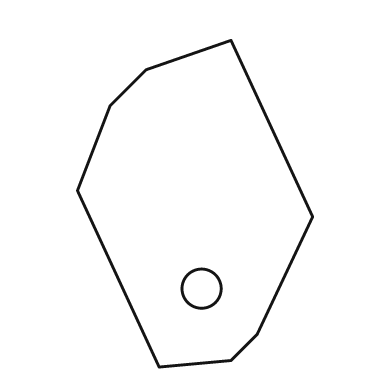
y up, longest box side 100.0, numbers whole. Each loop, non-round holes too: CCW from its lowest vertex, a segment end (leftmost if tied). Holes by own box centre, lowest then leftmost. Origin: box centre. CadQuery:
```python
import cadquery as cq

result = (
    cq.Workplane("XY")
    .moveTo(-11.0, -50.0)
    .lineTo(11.0, -48.0)
    .lineTo(19.0, -40.0)
    .lineTo(36.0, -4.0)
    .lineTo(11.0, 50.0)
    .lineTo(-15.0, 41.0)
    .lineTo(-26.0, 30.0)
    .lineTo(-36.0, 4.0)
    .close()
    .moveTo(2.0, -26.0)
    .circle(6.0)
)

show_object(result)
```